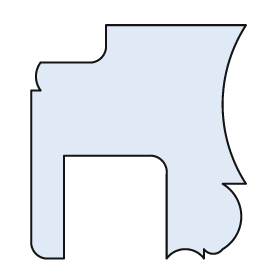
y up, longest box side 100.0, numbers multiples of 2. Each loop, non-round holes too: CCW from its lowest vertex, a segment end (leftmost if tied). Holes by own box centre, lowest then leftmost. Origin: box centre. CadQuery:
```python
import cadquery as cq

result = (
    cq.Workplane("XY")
    .moveTo(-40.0, -50.0)
    .lineTo(-32.0, -50.0)
    .lineTo(-32.0, -6.0)
    .lineTo(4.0, -6.0)
    .threePointArc((10.0, -8.0), (12.0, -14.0))
    .lineTo(12.0, -50.0)
    .threePointArc((20.0, -46.0), (28.0, -50.0))
    .lineTo(28.0, -46.0)
    .threePointArc((32.0, -48.0), (36.0, -46.0))
    .threePointArc((44.0, -32.0), (36.0, -18.0))
    .lineTo(46.0, -18.0)
    .threePointArc((36.0, 16.0), (46.0, 50.0))
    .lineTo(-14.0, 50.0)
    .lineTo(-14.0, 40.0)
    .threePointArc((-16.0, 36.0), (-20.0, 34.0))
    .lineTo(-42.0, 34.0)
    .threePointArc((-44.0, 28.0), (-42.0, 22.0))
    .lineTo(-46.0, 22.0)
    .lineTo(-46.0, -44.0)
    .threePointArc((-44.0, -48.0), (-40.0, -50.0))
    .close()
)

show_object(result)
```